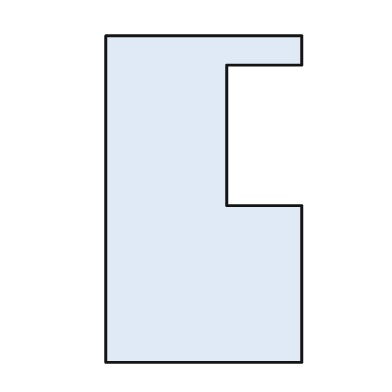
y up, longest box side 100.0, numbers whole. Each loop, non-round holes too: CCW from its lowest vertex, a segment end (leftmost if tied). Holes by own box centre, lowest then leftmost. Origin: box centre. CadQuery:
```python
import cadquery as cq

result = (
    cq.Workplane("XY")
    .moveTo(-30.0, -50.0)
    .lineTo(30.0, -50.0)
    .lineTo(30.0, -2.0)
    .lineTo(7.0, -2.0)
    .lineTo(7.0, 41.0)
    .lineTo(30.0, 41.0)
    .lineTo(30.0, 50.0)
    .lineTo(-30.0, 50.0)
    .close()
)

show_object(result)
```